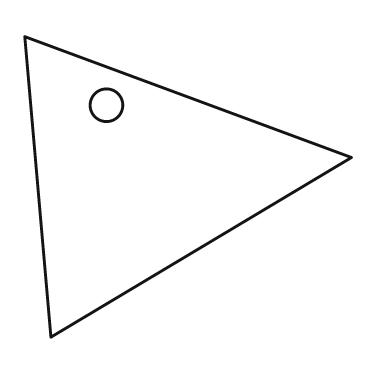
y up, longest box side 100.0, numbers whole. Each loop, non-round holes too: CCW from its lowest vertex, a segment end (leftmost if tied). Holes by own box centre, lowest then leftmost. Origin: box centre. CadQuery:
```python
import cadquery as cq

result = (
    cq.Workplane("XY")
    .moveTo(-42.0, -46.0)
    .lineTo(50.0, 9.0)
    .lineTo(-50.0, 46.0)
    .close()
    .moveTo(-25.0, 25.0)
    .circle(5.0)
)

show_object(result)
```